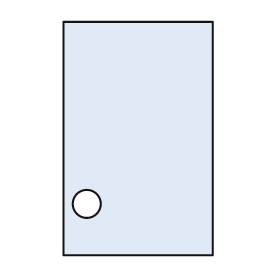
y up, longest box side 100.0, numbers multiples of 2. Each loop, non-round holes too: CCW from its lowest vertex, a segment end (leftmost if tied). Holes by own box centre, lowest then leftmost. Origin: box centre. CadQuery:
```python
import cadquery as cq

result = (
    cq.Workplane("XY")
    .moveTo(-32.0, -50.0)
    .lineTo(32.0, -50.0)
    .lineTo(32.0, 50.0)
    .lineTo(-32.0, 50.0)
    .close()
    .moveTo(-22.0, -28.0)
    .circle(6.0)
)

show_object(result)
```